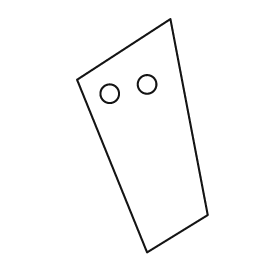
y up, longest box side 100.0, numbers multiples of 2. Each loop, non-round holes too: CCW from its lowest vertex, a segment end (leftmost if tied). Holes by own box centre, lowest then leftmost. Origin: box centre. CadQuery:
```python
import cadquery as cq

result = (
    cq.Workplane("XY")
    .moveTo(2.0, -50.0)
    .lineTo(28.0, -34.0)
    .lineTo(12.0, 50.0)
    .lineTo(-28.0, 24.0)
    .close()
    .moveTo(-14.0, 18.0)
    .circle(4.0)
    .moveTo(2.0, 22.0)
    .circle(4.0)
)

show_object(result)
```